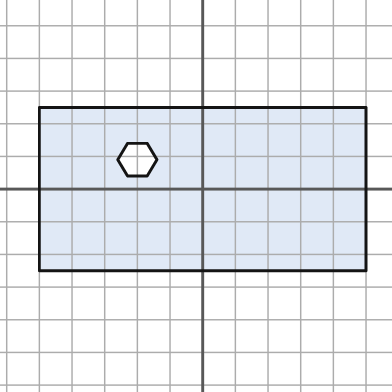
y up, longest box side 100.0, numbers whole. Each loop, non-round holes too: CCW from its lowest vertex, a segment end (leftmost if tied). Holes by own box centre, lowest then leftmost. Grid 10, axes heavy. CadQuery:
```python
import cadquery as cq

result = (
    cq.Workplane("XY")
    .moveTo(-50.0, -25.0)
    .lineTo(50.0, -25.0)
    .lineTo(50.0, 25.0)
    .lineTo(-50.0, 25.0)
    .close()
    .moveTo(-23.0, 4.0)
    .lineTo(-17.0, 4.0)
    .lineTo(-14.0, 9.0)
    .lineTo(-17.0, 14.0)
    .lineTo(-23.0, 14.0)
    .lineTo(-26.0, 9.0)
    .close()
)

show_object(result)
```